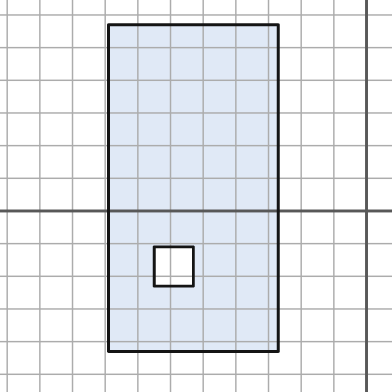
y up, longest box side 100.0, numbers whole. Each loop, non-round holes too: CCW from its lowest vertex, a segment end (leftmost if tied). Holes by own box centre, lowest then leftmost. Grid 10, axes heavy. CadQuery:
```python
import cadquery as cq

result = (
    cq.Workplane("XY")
    .moveTo(-79.0, -43.0)
    .lineTo(-27.0, -43.0)
    .lineTo(-27.0, 57.0)
    .lineTo(-79.0, 57.0)
    .close()
    .moveTo(-65.0, -23.0)
    .lineTo(-53.0, -23.0)
    .lineTo(-53.0, -11.0)
    .lineTo(-65.0, -11.0)
    .close()
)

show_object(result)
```